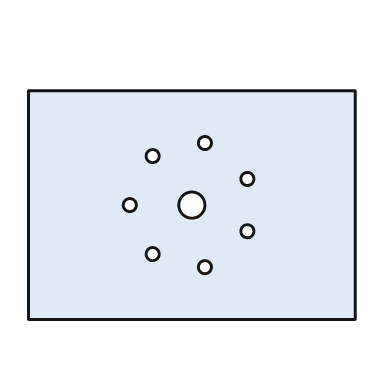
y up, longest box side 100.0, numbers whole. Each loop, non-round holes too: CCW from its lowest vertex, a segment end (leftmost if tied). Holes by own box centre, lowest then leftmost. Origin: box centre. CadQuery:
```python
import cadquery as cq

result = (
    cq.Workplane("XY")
    .moveTo(-50.0, -35.0)
    .lineTo(50.0, -35.0)
    .lineTo(50.0, 35.0)
    .lineTo(-50.0, 35.0)
    .close()
    .moveTo(4.0, -19.0)
    .circle(2.0)
    .moveTo(-12.0, -15.0)
    .circle(2.0)
    .moveTo(17.0, -8.0)
    .circle(2.0)
    .moveTo(-19.0, 0.0)
    .circle(2.0)
    .moveTo(0.0, 0.0)
    .circle(4.0)
    .moveTo(17.0, 8.0)
    .circle(2.0)
    .moveTo(-12.0, 15.0)
    .circle(2.0)
    .moveTo(4.0, 19.0)
    .circle(2.0)
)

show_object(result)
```